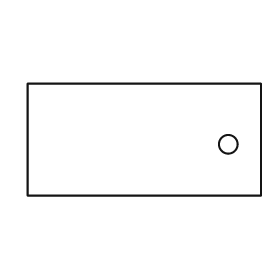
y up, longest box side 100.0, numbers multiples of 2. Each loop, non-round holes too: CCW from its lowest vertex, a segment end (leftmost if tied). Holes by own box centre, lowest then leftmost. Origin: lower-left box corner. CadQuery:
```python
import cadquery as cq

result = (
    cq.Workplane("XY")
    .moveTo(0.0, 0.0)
    .lineTo(100.0, 0.0)
    .lineTo(100.0, 48.0)
    .lineTo(0.0, 48.0)
    .close()
    .moveTo(86.0, 22.0)
    .circle(4.0)
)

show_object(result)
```